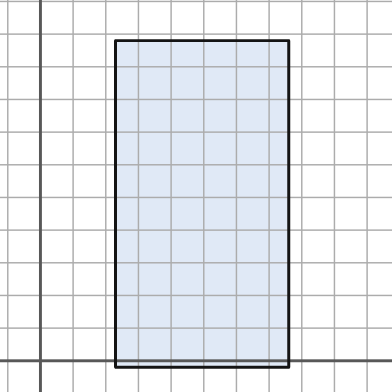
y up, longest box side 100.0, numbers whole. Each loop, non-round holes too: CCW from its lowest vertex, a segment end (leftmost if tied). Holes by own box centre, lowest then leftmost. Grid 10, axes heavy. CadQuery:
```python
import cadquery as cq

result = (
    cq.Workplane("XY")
    .moveTo(23.0, -2.0)
    .lineTo(76.0, -2.0)
    .lineTo(76.0, 98.0)
    .lineTo(23.0, 98.0)
    .close()
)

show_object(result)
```